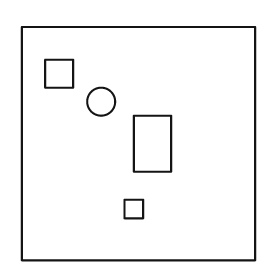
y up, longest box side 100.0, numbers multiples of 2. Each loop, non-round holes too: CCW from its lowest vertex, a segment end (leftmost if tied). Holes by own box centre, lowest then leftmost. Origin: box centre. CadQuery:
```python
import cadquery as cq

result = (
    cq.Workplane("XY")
    .moveTo(-50.0, -50.0)
    .lineTo(50.0, -50.0)
    .lineTo(50.0, 50.0)
    .lineTo(-50.0, 50.0)
    .close()
    .moveTo(-6.0, -32.0)
    .lineTo(2.0, -32.0)
    .lineTo(2.0, -24.0)
    .lineTo(-6.0, -24.0)
    .close()
    .moveTo(-2.0, -12.0)
    .lineTo(14.0, -12.0)
    .lineTo(14.0, 12.0)
    .lineTo(-2.0, 12.0)
    .close()
    .moveTo(-16.0, 18.0)
    .circle(6.0)
    .moveTo(-40.0, 24.0)
    .lineTo(-28.0, 24.0)
    .lineTo(-28.0, 36.0)
    .lineTo(-40.0, 36.0)
    .close()
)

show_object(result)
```